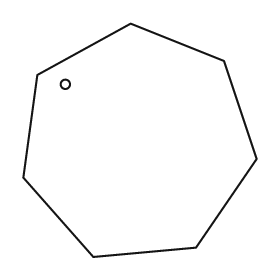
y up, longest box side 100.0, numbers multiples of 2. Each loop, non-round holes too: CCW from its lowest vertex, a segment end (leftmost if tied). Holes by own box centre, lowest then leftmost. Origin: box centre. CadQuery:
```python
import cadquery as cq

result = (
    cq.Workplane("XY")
    .moveTo(-20.0, -50.0)
    .lineTo(24.0, -46.0)
    .lineTo(50.0, -8.0)
    .lineTo(36.0, 34.0)
    .lineTo(-4.0, 50.0)
    .lineTo(-44.0, 28.0)
    .lineTo(-50.0, -16.0)
    .close()
    .moveTo(-32.0, 24.0)
    .circle(2.0)
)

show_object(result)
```